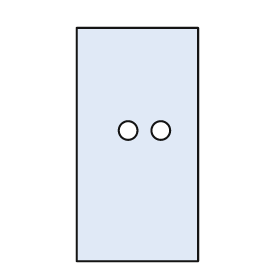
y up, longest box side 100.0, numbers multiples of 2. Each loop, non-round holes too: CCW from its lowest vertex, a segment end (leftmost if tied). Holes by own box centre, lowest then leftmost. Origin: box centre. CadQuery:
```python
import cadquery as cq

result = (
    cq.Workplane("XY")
    .moveTo(-26.0, -50.0)
    .lineTo(26.0, -50.0)
    .lineTo(26.0, 50.0)
    .lineTo(-26.0, 50.0)
    .close()
    .moveTo(-4.0, 6.0)
    .circle(4.0)
    .moveTo(10.0, 6.0)
    .circle(4.0)
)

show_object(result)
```